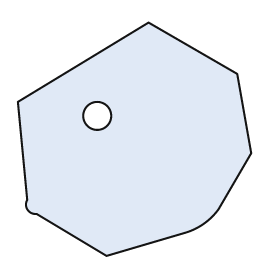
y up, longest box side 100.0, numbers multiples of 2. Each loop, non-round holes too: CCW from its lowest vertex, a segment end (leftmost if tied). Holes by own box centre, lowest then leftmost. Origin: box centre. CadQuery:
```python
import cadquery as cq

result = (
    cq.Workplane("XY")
    .moveTo(-12.0, -50.0)
    .lineTo(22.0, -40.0)
    .threePointArc((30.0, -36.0), (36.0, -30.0))
    .lineTo(50.0, -6.0)
    .lineTo(44.0, 28.0)
    .lineTo(6.0, 50.0)
    .lineTo(-50.0, 16.0)
    .lineTo(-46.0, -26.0)
    .threePointArc((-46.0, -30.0), (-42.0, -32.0))
    .close()
    .moveTo(-16.0, 10.0)
    .circle(6.0)
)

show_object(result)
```